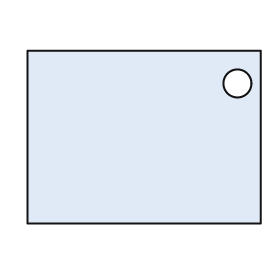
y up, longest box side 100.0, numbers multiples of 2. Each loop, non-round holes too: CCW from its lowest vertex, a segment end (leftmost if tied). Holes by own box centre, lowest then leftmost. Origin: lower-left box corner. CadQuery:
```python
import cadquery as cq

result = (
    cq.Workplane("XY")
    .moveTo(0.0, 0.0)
    .lineTo(100.0, 0.0)
    .lineTo(100.0, 74.0)
    .lineTo(0.0, 74.0)
    .close()
    .moveTo(90.0, 60.0)
    .circle(6.0)
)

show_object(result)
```